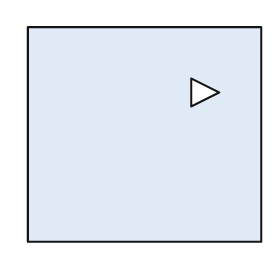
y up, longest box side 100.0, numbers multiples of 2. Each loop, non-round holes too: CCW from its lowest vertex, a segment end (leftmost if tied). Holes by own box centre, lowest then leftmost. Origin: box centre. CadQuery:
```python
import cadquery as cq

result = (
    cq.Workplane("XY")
    .moveTo(-50.0, -46.0)
    .lineTo(50.0, -46.0)
    .lineTo(50.0, 46.0)
    .lineTo(-50.0, 46.0)
    .close()
    .moveTo(20.0, 12.0)
    .lineTo(32.0, 18.0)
    .lineTo(20.0, 24.0)
    .close()
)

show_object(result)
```